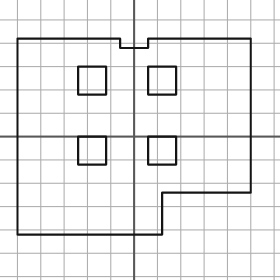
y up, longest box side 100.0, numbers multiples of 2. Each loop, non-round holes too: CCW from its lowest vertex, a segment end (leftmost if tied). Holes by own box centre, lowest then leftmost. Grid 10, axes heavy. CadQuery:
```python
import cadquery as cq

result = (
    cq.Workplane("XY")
    .moveTo(-50.0, -42.0)
    .lineTo(12.0, -42.0)
    .lineTo(12.0, -24.0)
    .lineTo(50.0, -24.0)
    .lineTo(50.0, 42.0)
    .lineTo(6.0, 42.0)
    .lineTo(6.0, 38.0)
    .lineTo(-6.0, 38.0)
    .lineTo(-6.0, 42.0)
    .lineTo(-50.0, 42.0)
    .close()
    .moveTo(-24.0, -12.0)
    .lineTo(-12.0, -12.0)
    .lineTo(-12.0, 0.0)
    .lineTo(-24.0, 0.0)
    .close()
    .moveTo(6.0, -12.0)
    .lineTo(18.0, -12.0)
    .lineTo(18.0, 0.0)
    .lineTo(6.0, 0.0)
    .close()
    .moveTo(-24.0, 18.0)
    .lineTo(-12.0, 18.0)
    .lineTo(-12.0, 30.0)
    .lineTo(-24.0, 30.0)
    .close()
    .moveTo(6.0, 18.0)
    .lineTo(18.0, 18.0)
    .lineTo(18.0, 30.0)
    .lineTo(6.0, 30.0)
    .close()
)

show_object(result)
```